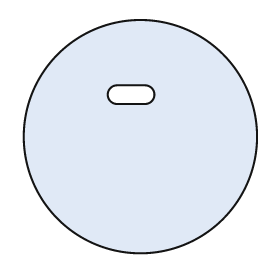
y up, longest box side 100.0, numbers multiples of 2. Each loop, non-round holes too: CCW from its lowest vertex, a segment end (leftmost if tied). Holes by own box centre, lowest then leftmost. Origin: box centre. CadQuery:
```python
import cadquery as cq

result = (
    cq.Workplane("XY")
    .moveTo(0.0, 0.0)
    .circle(50.0)
    .moveTo(-10.0, 14.0)
    .lineTo(2.0, 14.0)
    .threePointArc((6.0, 18.0), (2.0, 22.0))
    .lineTo(-10.0, 22.0)
    .threePointArc((-14.0, 18.0), (-10.0, 14.0))
    .close()
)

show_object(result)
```